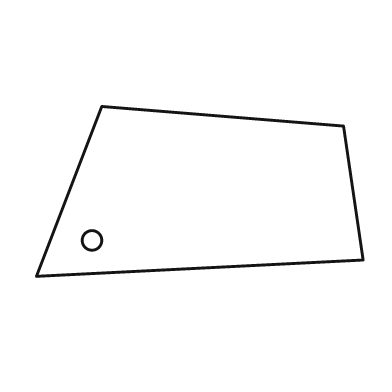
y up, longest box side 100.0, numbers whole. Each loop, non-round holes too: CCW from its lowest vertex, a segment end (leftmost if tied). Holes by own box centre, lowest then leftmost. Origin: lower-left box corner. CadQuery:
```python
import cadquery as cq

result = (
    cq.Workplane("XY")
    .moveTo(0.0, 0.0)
    .lineTo(100.0, 5.0)
    .lineTo(94.0, 46.0)
    .lineTo(20.0, 52.0)
    .close()
    .moveTo(17.0, 11.0)
    .circle(3.0)
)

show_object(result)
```